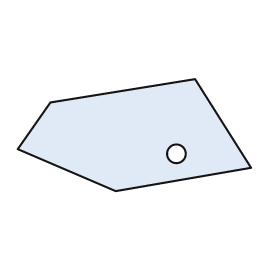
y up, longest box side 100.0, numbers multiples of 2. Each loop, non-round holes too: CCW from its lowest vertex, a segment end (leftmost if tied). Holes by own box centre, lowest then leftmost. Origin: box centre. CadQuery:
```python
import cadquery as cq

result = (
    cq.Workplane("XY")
    .moveTo(-8.0, -24.0)
    .lineTo(50.0, -14.0)
    .lineTo(26.0, 24.0)
    .lineTo(-36.0, 14.0)
    .lineTo(-50.0, -6.0)
    .close()
    .moveTo(18.0, -8.0)
    .circle(4.0)
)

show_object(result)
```